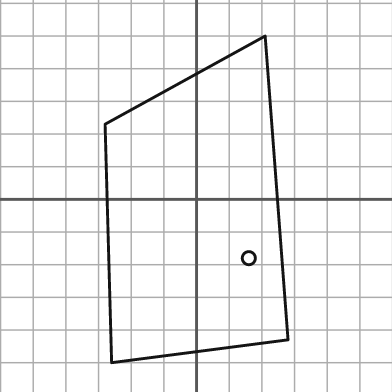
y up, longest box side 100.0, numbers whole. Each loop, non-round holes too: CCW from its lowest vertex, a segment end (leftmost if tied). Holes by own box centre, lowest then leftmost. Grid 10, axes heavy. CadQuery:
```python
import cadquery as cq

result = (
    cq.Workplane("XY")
    .moveTo(-26.0, -50.0)
    .lineTo(28.0, -43.0)
    .lineTo(21.0, 50.0)
    .lineTo(-28.0, 23.0)
    .close()
    .moveTo(16.0, -18.0)
    .circle(2.0)
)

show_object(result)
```